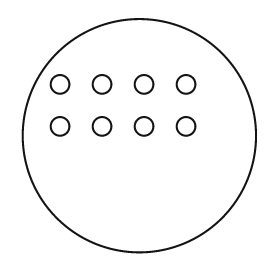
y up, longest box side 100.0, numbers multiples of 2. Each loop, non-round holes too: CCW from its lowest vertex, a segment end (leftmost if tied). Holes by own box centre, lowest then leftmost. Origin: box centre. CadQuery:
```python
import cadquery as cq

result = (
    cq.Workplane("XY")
    .moveTo(0.0, 0.0)
    .circle(50.0)
    .moveTo(-34.0, 4.0)
    .circle(4.0)
    .moveTo(-16.0, 4.0)
    .circle(4.0)
    .moveTo(2.0, 4.0)
    .circle(4.0)
    .moveTo(20.0, 4.0)
    .circle(4.0)
    .moveTo(-34.0, 22.0)
    .circle(4.0)
    .moveTo(-16.0, 22.0)
    .circle(4.0)
    .moveTo(2.0, 22.0)
    .circle(4.0)
    .moveTo(20.0, 22.0)
    .circle(4.0)
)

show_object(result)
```